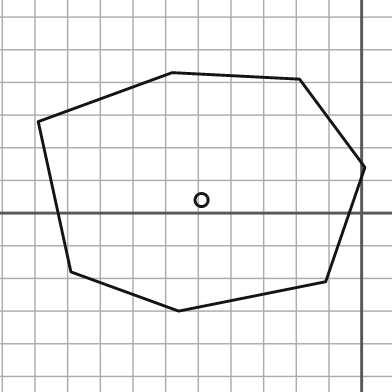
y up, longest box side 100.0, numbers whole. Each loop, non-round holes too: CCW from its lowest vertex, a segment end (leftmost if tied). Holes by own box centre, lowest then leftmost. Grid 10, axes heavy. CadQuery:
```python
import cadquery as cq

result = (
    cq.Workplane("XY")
    .moveTo(-56.0, -30.0)
    .lineTo(-11.0, -21.0)
    .lineTo(1.0, 14.0)
    .lineTo(-19.0, 41.0)
    .lineTo(-58.0, 43.0)
    .lineTo(-99.0, 28.0)
    .lineTo(-89.0, -18.0)
    .close()
    .moveTo(-49.0, 4.0)
    .circle(2.0)
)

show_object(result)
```